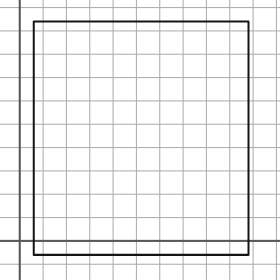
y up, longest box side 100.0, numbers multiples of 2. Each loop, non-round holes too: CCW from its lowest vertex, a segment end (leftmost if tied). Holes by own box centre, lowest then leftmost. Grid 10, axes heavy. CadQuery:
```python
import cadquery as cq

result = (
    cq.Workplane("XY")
    .moveTo(6.0, -6.0)
    .lineTo(98.0, -6.0)
    .lineTo(98.0, 94.0)
    .lineTo(6.0, 94.0)
    .close()
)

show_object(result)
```